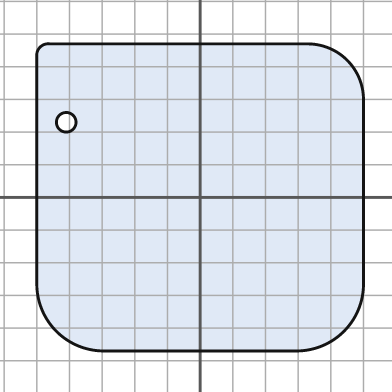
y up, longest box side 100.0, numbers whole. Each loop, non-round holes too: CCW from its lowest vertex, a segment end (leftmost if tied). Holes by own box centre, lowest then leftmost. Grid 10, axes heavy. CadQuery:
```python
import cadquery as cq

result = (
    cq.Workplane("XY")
    .moveTo(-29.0, -47.0)
    .lineTo(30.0, -47.0)
    .threePointArc((44.0, -41.0), (50.0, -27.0))
    .lineTo(50.0, 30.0)
    .threePointArc((45.0, 42.0), (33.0, 47.0))
    .lineTo(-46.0, 47.0)
    .threePointArc((-49.0, 46.0), (-50.0, 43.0))
    .lineTo(-50.0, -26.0)
    .threePointArc((-44.0, -41.0), (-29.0, -47.0))
    .close()
    .moveTo(-41.0, 23.0)
    .circle(3.0)
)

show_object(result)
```